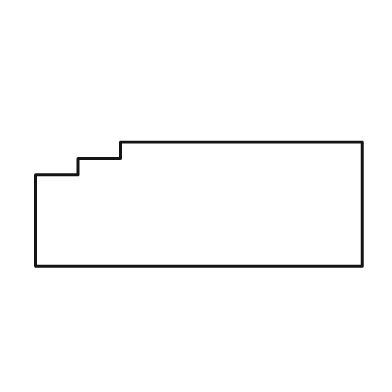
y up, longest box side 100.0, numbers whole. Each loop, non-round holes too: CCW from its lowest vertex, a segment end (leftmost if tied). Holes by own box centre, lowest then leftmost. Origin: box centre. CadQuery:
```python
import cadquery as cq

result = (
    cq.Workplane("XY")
    .moveTo(-50.0, -19.0)
    .lineTo(50.0, -19.0)
    .lineTo(50.0, 19.0)
    .lineTo(-24.0, 19.0)
    .lineTo(-24.0, 14.0)
    .lineTo(-37.0, 14.0)
    .lineTo(-37.0, 9.0)
    .lineTo(-50.0, 9.0)
    .close()
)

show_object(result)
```